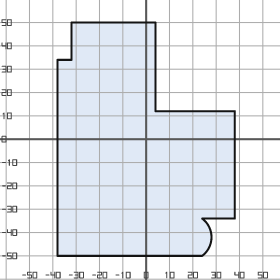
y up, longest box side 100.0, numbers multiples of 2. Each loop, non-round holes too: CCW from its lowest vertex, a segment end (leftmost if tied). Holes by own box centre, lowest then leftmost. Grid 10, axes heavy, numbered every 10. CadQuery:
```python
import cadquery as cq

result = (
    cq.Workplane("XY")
    .moveTo(-38.0, -50.0)
    .lineTo(24.0, -50.0)
    .threePointArc((28.0, -42.0), (24.0, -34.0))
    .lineTo(38.0, -34.0)
    .lineTo(38.0, 12.0)
    .lineTo(4.0, 12.0)
    .lineTo(4.0, 50.0)
    .lineTo(-32.0, 50.0)
    .lineTo(-32.0, 34.0)
    .lineTo(-38.0, 34.0)
    .close()
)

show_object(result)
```